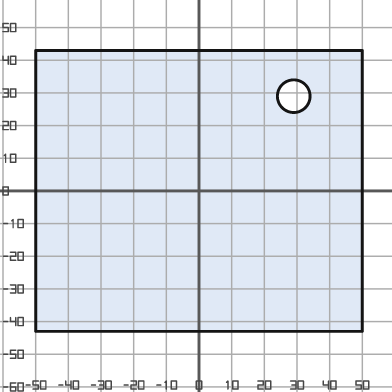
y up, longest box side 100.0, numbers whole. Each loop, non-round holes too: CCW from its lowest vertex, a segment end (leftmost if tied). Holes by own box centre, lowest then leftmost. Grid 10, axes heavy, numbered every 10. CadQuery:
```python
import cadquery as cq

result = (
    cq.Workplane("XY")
    .moveTo(-50.0, -43.0)
    .lineTo(50.0, -43.0)
    .lineTo(50.0, 43.0)
    .lineTo(-50.0, 43.0)
    .close()
    .moveTo(29.0, 29.0)
    .circle(5.0)
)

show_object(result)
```